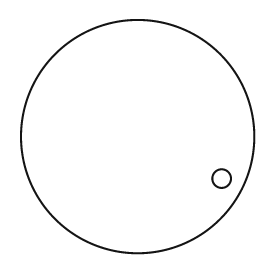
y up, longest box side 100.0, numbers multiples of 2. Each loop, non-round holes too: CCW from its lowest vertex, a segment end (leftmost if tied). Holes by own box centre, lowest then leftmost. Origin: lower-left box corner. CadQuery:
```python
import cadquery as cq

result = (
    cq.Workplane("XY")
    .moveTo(50.0, 50.0)
    .circle(50.0)
    .moveTo(86.0, 32.0)
    .circle(4.0)
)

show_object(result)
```